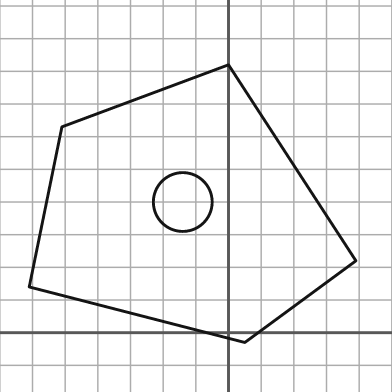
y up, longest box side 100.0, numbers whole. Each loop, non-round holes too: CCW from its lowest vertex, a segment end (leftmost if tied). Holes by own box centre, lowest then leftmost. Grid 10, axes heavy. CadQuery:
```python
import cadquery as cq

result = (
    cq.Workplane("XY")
    .moveTo(5.0, -3.0)
    .lineTo(39.0, 22.0)
    .lineTo(0.0, 82.0)
    .lineTo(-51.0, 63.0)
    .lineTo(-61.0, 14.0)
    .close()
    .moveTo(-14.0, 40.0)
    .circle(9.0)
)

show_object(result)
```